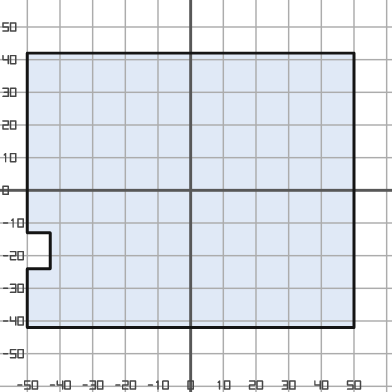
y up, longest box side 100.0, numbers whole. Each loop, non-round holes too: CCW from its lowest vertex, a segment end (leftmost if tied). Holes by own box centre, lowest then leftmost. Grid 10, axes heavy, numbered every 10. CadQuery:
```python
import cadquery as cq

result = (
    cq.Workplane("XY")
    .moveTo(-50.0, -42.0)
    .lineTo(50.0, -42.0)
    .lineTo(50.0, 42.0)
    .lineTo(-50.0, 42.0)
    .lineTo(-50.0, -13.0)
    .lineTo(-43.0, -13.0)
    .lineTo(-43.0, -24.0)
    .lineTo(-50.0, -24.0)
    .close()
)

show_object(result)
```